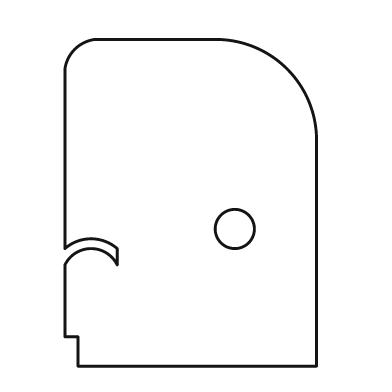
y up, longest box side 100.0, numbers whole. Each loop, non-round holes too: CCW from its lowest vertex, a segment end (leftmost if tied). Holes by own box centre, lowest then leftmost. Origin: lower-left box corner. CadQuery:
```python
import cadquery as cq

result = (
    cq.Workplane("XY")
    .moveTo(4.0, 0.0)
    .lineTo(77.0, 0.0)
    .lineTo(77.0, 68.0)
    .threePointArc((68.0, 91.0), (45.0, 100.0))
    .lineTo(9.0, 100.0)
    .threePointArc((3.0, 97.0), (0.0, 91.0))
    .lineTo(0.0, 36.0)
    .threePointArc((8.0, 39.0), (16.0, 36.0))
    .lineTo(16.0, 31.0)
    .threePointArc((8.0, 36.0), (0.0, 31.0))
    .lineTo(0.0, 9.0)
    .lineTo(4.0, 9.0)
    .close()
    .moveTo(52.0, 42.0)
    .circle(6.0)
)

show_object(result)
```